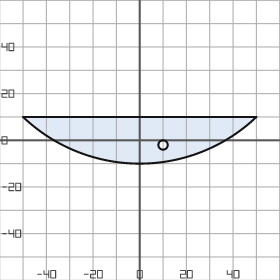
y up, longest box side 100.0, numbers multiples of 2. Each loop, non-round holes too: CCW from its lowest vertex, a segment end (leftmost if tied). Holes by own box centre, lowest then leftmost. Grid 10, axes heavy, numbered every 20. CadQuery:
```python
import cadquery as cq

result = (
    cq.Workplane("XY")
    .moveTo(-50.0, 10.0)
    .threePointArc((0.0, -10.0), (50.0, 10.0))
    .close()
    .moveTo(10.0, -2.0)
    .circle(2.0)
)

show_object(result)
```